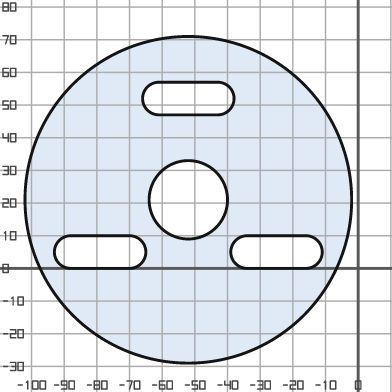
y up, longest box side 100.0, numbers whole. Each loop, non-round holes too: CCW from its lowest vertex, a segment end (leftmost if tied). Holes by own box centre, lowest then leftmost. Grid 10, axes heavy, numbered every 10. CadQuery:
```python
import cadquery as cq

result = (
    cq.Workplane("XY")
    .moveTo(-52.0, 21.0)
    .circle(50.0)
    .moveTo(-88.0, 0.0)
    .lineTo(-70.0, 0.0)
    .threePointArc((-65.0, 5.0), (-70.0, 10.0))
    .lineTo(-88.0, 10.0)
    .threePointArc((-93.0, 5.0), (-88.0, 0.0))
    .close()
    .moveTo(-34.0, 0.0)
    .lineTo(-16.0, 0.0)
    .threePointArc((-11.0, 5.0), (-16.0, 10.0))
    .lineTo(-34.0, 10.0)
    .threePointArc((-39.0, 5.0), (-34.0, 0.0))
    .close()
    .moveTo(-52.0, 21.0)
    .circle(12.0)
    .moveTo(-61.0, 47.0)
    .lineTo(-43.0, 47.0)
    .threePointArc((-38.0, 52.0), (-43.0, 57.0))
    .lineTo(-61.0, 57.0)
    .threePointArc((-66.0, 52.0), (-61.0, 47.0))
    .close()
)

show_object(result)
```